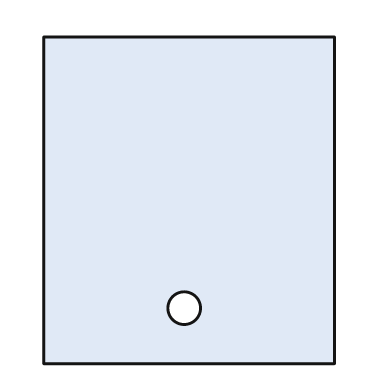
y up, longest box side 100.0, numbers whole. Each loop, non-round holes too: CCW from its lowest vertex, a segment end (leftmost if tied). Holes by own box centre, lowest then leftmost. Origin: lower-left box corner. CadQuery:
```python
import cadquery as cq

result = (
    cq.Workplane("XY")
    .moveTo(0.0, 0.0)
    .lineTo(89.0, 0.0)
    .lineTo(89.0, 100.0)
    .lineTo(0.0, 100.0)
    .close()
    .moveTo(43.0, 17.0)
    .circle(5.0)
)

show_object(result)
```